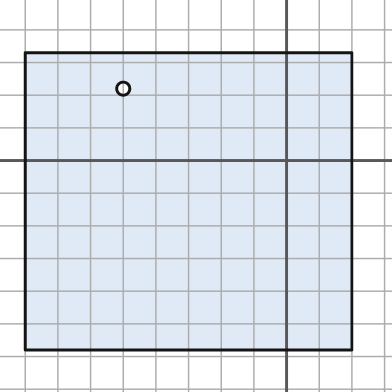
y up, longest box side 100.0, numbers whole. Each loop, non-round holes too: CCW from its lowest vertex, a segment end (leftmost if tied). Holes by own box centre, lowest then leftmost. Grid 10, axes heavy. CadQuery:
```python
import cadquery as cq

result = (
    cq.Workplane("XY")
    .moveTo(-80.0, -58.0)
    .lineTo(20.0, -58.0)
    .lineTo(20.0, 33.0)
    .lineTo(-80.0, 33.0)
    .close()
    .moveTo(-50.0, 22.0)
    .circle(2.0)
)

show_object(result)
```